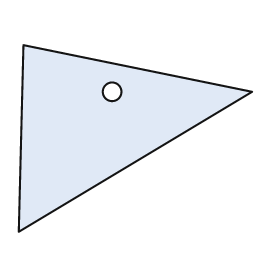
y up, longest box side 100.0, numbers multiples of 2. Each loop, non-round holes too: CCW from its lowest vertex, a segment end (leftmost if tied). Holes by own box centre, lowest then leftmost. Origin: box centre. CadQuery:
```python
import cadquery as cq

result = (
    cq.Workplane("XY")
    .moveTo(-50.0, -40.0)
    .lineTo(50.0, 20.0)
    .lineTo(-48.0, 40.0)
    .close()
    .moveTo(-10.0, 20.0)
    .circle(4.0)
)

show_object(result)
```